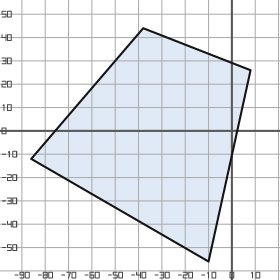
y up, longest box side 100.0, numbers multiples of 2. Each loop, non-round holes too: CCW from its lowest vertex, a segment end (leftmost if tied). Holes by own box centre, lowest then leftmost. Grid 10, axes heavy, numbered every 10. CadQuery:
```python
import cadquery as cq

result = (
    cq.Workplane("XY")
    .moveTo(-10.0, -56.0)
    .lineTo(8.0, 26.0)
    .lineTo(-38.0, 44.0)
    .lineTo(-86.0, -12.0)
    .close()
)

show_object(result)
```